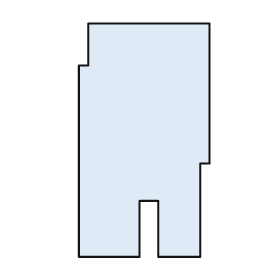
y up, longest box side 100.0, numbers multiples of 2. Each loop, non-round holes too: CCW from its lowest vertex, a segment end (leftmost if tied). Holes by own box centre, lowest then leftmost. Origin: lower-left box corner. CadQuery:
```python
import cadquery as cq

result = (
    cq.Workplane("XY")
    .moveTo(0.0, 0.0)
    .lineTo(26.0, 0.0)
    .lineTo(26.0, 24.0)
    .lineTo(34.0, 24.0)
    .lineTo(34.0, 0.0)
    .lineTo(52.0, 0.0)
    .lineTo(52.0, 40.0)
    .lineTo(56.0, 40.0)
    .lineTo(56.0, 100.0)
    .lineTo(4.0, 100.0)
    .lineTo(4.0, 82.0)
    .lineTo(0.0, 82.0)
    .close()
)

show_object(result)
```